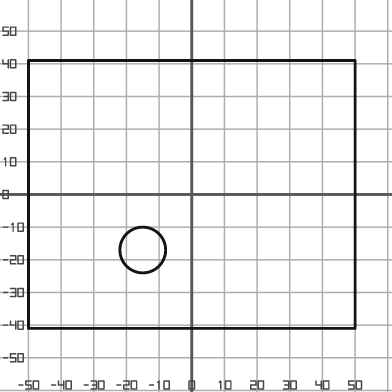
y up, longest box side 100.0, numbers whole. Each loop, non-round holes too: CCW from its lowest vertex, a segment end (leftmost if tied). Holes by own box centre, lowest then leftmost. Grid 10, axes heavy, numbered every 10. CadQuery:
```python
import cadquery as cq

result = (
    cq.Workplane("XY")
    .moveTo(-50.0, -41.0)
    .lineTo(50.0, -41.0)
    .lineTo(50.0, 41.0)
    .lineTo(-50.0, 41.0)
    .close()
    .moveTo(-15.0, -17.0)
    .circle(7.0)
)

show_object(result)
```